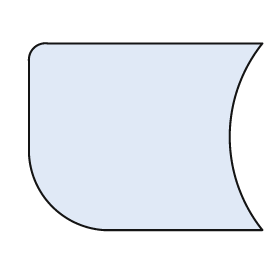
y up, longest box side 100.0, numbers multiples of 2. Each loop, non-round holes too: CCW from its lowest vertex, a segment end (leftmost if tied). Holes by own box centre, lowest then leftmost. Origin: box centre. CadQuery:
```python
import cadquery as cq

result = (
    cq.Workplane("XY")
    .moveTo(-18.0, -40.0)
    .lineTo(50.0, -40.0)
    .threePointArc((36.0, 0.0), (50.0, 40.0))
    .lineTo(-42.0, 40.0)
    .threePointArc((-48.0, 38.0), (-50.0, 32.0))
    .lineTo(-50.0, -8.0)
    .threePointArc((-40.0, -30.0), (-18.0, -40.0))
    .close()
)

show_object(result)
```